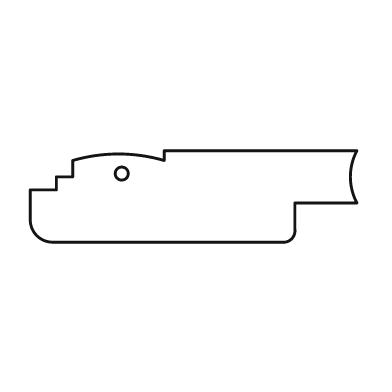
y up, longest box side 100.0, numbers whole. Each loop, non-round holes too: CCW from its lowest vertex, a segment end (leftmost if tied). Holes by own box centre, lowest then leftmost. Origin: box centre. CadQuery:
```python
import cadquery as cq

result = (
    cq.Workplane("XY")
    .moveTo(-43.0, -14.0)
    .lineTo(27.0, -14.0)
    .threePointArc((30.0, -13.0), (31.0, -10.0))
    .lineTo(31.0, -2.0)
    .lineTo(50.0, -2.0)
    .threePointArc((48.0, 6.0), (50.0, 14.0))
    .lineTo(-9.0, 14.0)
    .lineTo(-9.0, 11.0)
    .threePointArc((-23.0, 13.0), (-37.0, 11.0))
    .lineTo(-37.0, 6.0)
    .lineTo(-42.0, 6.0)
    .lineTo(-42.0, 2.0)
    .lineTo(-50.0, 2.0)
    .lineTo(-50.0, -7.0)
    .threePointArc((-48.0, -12.0), (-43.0, -14.0))
    .close()
    .moveTo(-22.0, 7.0)
    .circle(2.0)
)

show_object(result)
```